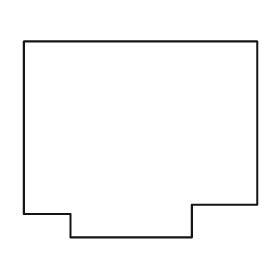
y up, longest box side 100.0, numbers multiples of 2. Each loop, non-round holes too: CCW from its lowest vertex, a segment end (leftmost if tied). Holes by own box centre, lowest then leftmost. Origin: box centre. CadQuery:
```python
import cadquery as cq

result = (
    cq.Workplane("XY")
    .moveTo(-30.0, -42.0)
    .lineTo(22.0, -42.0)
    .lineTo(22.0, -28.0)
    .lineTo(50.0, -28.0)
    .lineTo(50.0, 42.0)
    .lineTo(-50.0, 42.0)
    .lineTo(-50.0, -32.0)
    .lineTo(-30.0, -32.0)
    .close()
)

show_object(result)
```